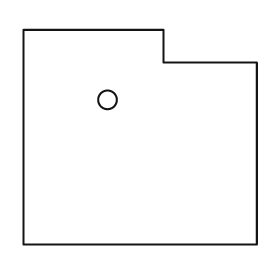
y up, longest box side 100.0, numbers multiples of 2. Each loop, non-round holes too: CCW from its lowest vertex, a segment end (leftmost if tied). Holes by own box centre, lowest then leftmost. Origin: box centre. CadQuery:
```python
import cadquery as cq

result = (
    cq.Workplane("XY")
    .moveTo(-50.0, -46.0)
    .lineTo(50.0, -46.0)
    .lineTo(50.0, 32.0)
    .lineTo(10.0, 32.0)
    .lineTo(10.0, 46.0)
    .lineTo(-50.0, 46.0)
    .close()
    .moveTo(-14.0, 16.0)
    .circle(4.0)
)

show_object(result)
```